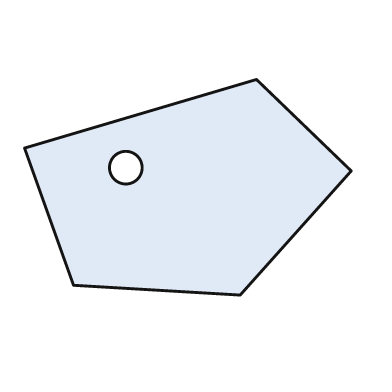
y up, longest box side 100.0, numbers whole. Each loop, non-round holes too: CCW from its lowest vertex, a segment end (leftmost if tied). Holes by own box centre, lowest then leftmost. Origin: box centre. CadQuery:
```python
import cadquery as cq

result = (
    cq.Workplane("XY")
    .moveTo(16.0, -33.0)
    .lineTo(50.0, 5.0)
    .lineTo(21.0, 33.0)
    .lineTo(-50.0, 12.0)
    .lineTo(-35.0, -30.0)
    .close()
    .moveTo(-19.0, 6.0)
    .circle(5.0)
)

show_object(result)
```